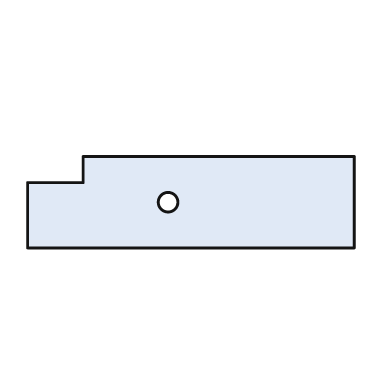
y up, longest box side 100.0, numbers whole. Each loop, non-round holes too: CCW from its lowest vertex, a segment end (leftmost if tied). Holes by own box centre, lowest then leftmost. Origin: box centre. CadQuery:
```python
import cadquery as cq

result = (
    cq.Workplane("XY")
    .moveTo(-50.0, -14.0)
    .lineTo(50.0, -14.0)
    .lineTo(50.0, 14.0)
    .lineTo(-33.0, 14.0)
    .lineTo(-33.0, 6.0)
    .lineTo(-50.0, 6.0)
    .close()
    .moveTo(-7.0, 0.0)
    .circle(3.0)
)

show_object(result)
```